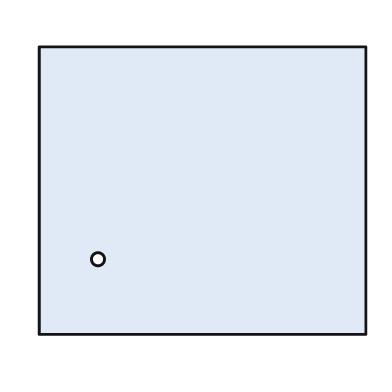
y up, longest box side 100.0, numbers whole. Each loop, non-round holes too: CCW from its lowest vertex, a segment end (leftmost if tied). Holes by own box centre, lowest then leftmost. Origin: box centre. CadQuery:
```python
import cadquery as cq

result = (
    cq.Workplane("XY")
    .moveTo(-50.0, -44.0)
    .lineTo(50.0, -44.0)
    .lineTo(50.0, 44.0)
    .lineTo(-50.0, 44.0)
    .close()
    .moveTo(-32.0, -21.0)
    .circle(2.0)
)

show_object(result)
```